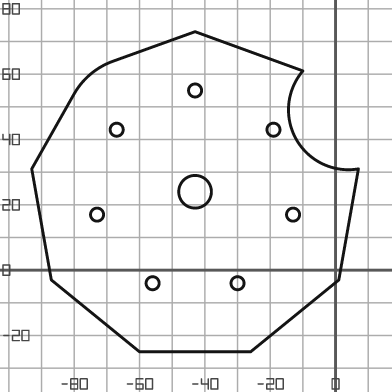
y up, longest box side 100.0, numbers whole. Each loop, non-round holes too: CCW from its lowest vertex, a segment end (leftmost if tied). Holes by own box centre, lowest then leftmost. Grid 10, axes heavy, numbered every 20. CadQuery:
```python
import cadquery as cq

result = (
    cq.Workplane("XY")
    .moveTo(-60.0, -25.0)
    .lineTo(-26.0, -25.0)
    .lineTo(1.0, -3.0)
    .lineTo(7.0, 31.0)
    .threePointArc((-12.0, 40.0), (-10.0, 61.0))
    .lineTo(-43.0, 73.0)
    .lineTo(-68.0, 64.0)
    .threePointArc((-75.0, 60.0), (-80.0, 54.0))
    .lineTo(-93.0, 31.0)
    .lineTo(-87.0, -3.0)
    .close()
    .moveTo(-56.0, -4.0)
    .circle(2.0)
    .moveTo(-30.0, -4.0)
    .circle(2.0)
    .moveTo(-73.0, 17.0)
    .circle(2.0)
    .moveTo(-13.0, 17.0)
    .circle(2.0)
    .moveTo(-43.0, 24.0)
    .circle(5.0)
    .moveTo(-67.0, 43.0)
    .circle(2.0)
    .moveTo(-19.0, 43.0)
    .circle(2.0)
    .moveTo(-43.0, 55.0)
    .circle(2.0)
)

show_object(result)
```